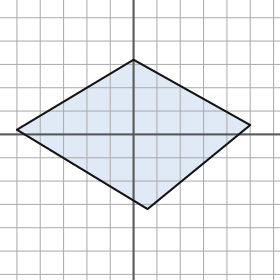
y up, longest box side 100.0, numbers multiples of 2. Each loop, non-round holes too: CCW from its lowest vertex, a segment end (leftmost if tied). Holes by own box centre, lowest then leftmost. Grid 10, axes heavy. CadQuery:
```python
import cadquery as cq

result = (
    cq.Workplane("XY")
    .moveTo(6.0, -32.0)
    .lineTo(50.0, 4.0)
    .lineTo(0.0, 32.0)
    .lineTo(-50.0, 2.0)
    .close()
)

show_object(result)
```